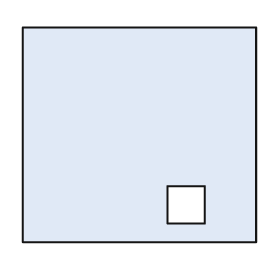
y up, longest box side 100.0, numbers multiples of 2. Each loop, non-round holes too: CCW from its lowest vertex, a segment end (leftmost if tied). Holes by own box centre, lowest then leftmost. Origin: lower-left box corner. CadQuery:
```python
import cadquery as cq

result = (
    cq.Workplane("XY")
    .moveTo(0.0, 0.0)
    .lineTo(100.0, 0.0)
    .lineTo(100.0, 92.0)
    .lineTo(0.0, 92.0)
    .close()
    .moveTo(62.0, 8.0)
    .lineTo(78.0, 8.0)
    .lineTo(78.0, 24.0)
    .lineTo(62.0, 24.0)
    .close()
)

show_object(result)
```